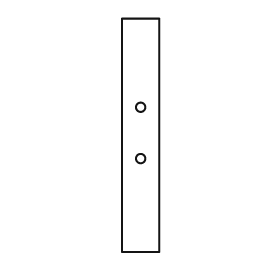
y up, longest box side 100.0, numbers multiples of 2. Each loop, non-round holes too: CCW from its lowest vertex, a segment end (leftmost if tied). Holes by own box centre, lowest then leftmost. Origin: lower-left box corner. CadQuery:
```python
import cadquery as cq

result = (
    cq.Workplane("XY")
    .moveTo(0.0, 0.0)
    .lineTo(16.0, 0.0)
    .lineTo(16.0, 100.0)
    .lineTo(0.0, 100.0)
    .close()
    .moveTo(8.0, 40.0)
    .circle(2.0)
    .moveTo(8.0, 62.0)
    .circle(2.0)
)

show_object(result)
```